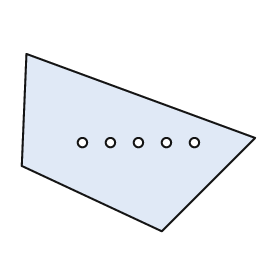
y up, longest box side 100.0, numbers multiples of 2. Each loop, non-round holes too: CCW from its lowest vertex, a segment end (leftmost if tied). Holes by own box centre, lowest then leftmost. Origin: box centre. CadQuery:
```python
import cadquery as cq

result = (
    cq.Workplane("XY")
    .moveTo(10.0, -38.0)
    .lineTo(50.0, 2.0)
    .lineTo(-48.0, 38.0)
    .lineTo(-50.0, -10.0)
    .close()
    .moveTo(-24.0, 0.0)
    .circle(2.0)
    .moveTo(-12.0, 0.0)
    .circle(2.0)
    .moveTo(0.0, 0.0)
    .circle(2.0)
    .moveTo(12.0, 0.0)
    .circle(2.0)
    .moveTo(24.0, 0.0)
    .circle(2.0)
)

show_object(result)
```